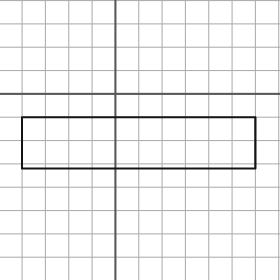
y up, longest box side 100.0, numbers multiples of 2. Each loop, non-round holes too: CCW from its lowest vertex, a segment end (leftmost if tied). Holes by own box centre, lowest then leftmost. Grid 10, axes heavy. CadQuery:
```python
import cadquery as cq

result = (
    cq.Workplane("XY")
    .moveTo(-40.0, -32.0)
    .lineTo(60.0, -32.0)
    .lineTo(60.0, -10.0)
    .lineTo(-40.0, -10.0)
    .close()
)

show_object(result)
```